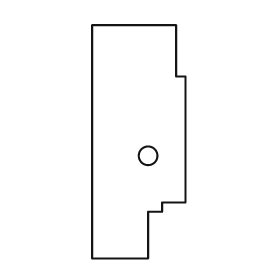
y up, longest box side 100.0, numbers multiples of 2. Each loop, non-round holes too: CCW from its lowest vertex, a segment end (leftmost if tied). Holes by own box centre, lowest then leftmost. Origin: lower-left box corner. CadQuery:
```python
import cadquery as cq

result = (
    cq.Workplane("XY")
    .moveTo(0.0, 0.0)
    .lineTo(24.0, 0.0)
    .lineTo(24.0, 20.0)
    .lineTo(30.0, 20.0)
    .lineTo(30.0, 24.0)
    .lineTo(40.0, 24.0)
    .lineTo(40.0, 78.0)
    .lineTo(36.0, 78.0)
    .lineTo(36.0, 100.0)
    .lineTo(0.0, 100.0)
    .close()
    .moveTo(24.0, 44.0)
    .circle(4.0)
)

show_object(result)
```